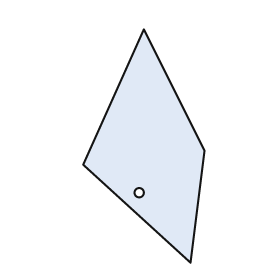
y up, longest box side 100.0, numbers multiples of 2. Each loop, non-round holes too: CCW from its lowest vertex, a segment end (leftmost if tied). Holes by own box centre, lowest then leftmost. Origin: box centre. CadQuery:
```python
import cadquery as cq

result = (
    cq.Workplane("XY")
    .moveTo(20.0, -50.0)
    .lineTo(26.0, -2.0)
    .lineTo(0.0, 50.0)
    .lineTo(-26.0, -8.0)
    .close()
    .moveTo(-2.0, -20.0)
    .circle(2.0)
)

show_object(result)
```